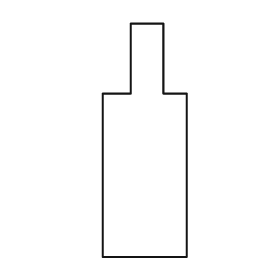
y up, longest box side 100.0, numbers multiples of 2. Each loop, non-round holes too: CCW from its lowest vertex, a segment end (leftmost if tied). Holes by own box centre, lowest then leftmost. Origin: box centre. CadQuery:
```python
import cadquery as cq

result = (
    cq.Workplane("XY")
    .moveTo(-18.0, -50.0)
    .lineTo(18.0, -50.0)
    .lineTo(18.0, 20.0)
    .lineTo(8.0, 20.0)
    .lineTo(8.0, 50.0)
    .lineTo(-6.0, 50.0)
    .lineTo(-6.0, 20.0)
    .lineTo(-18.0, 20.0)
    .close()
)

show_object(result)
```